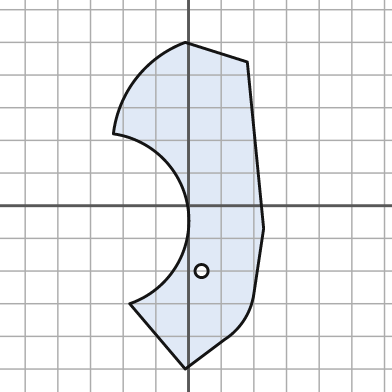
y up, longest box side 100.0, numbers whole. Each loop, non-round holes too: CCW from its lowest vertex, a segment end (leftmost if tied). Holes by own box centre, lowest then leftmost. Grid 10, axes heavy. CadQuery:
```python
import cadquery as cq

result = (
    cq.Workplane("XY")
    .moveTo(-1.0, -50.0)
    .lineTo(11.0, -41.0)
    .threePointArc((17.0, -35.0), (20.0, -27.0))
    .lineTo(23.0, -7.0)
    .lineTo(18.0, 44.0)
    .lineTo(-1.0, 50.0)
    .threePointArc((-16.0, 39.0), (-23.0, 22.0))
    .threePointArc((0.0, -2.0), (-18.0, -30.0))
    .close()
    .moveTo(4.0, -20.0)
    .circle(2.0)
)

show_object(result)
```